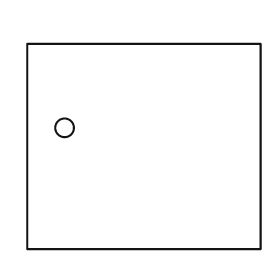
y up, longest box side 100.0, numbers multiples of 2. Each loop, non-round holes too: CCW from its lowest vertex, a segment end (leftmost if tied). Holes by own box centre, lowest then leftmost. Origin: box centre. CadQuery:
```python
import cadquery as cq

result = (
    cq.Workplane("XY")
    .moveTo(-50.0, -44.0)
    .lineTo(50.0, -44.0)
    .lineTo(50.0, 44.0)
    .lineTo(-50.0, 44.0)
    .close()
    .moveTo(-34.0, 8.0)
    .circle(4.0)
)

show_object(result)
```